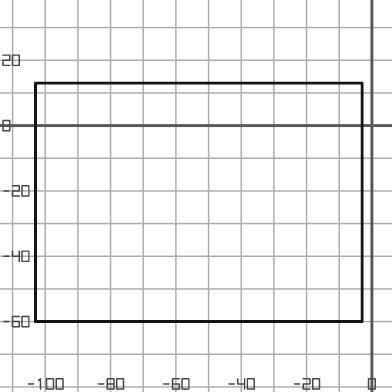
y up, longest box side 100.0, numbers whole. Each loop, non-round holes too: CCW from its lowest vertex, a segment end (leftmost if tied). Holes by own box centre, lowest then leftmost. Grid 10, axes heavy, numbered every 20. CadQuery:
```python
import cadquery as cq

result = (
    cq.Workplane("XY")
    .moveTo(-103.0, -60.0)
    .lineTo(-3.0, -60.0)
    .lineTo(-3.0, 13.0)
    .lineTo(-103.0, 13.0)
    .close()
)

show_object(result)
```